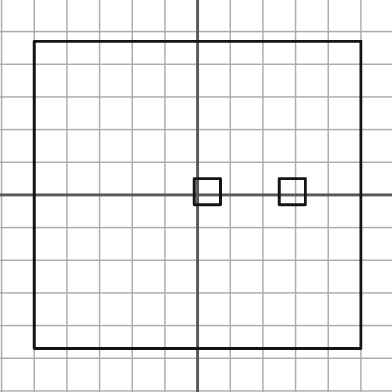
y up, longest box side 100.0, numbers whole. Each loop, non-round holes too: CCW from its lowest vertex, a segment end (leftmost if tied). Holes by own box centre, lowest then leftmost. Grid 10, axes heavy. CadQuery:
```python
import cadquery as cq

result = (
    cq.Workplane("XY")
    .moveTo(-50.0, -47.0)
    .lineTo(50.0, -47.0)
    .lineTo(50.0, 47.0)
    .lineTo(-50.0, 47.0)
    .close()
    .moveTo(-1.0, -3.0)
    .lineTo(7.0, -3.0)
    .lineTo(7.0, 5.0)
    .lineTo(-1.0, 5.0)
    .close()
    .moveTo(25.0, -3.0)
    .lineTo(33.0, -3.0)
    .lineTo(33.0, 5.0)
    .lineTo(25.0, 5.0)
    .close()
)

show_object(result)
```